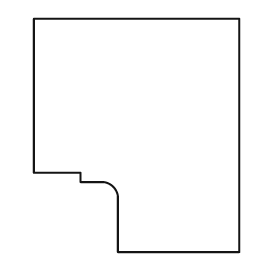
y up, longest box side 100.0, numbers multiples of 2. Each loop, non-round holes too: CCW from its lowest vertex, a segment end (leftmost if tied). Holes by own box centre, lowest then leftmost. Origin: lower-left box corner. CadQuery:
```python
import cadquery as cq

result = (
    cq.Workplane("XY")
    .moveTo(36.0, 0.0)
    .lineTo(88.0, 0.0)
    .lineTo(88.0, 100.0)
    .lineTo(0.0, 100.0)
    .lineTo(0.0, 34.0)
    .lineTo(20.0, 34.0)
    .lineTo(20.0, 30.0)
    .lineTo(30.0, 30.0)
    .threePointArc((34.0, 28.0), (36.0, 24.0))
    .close()
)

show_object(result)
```